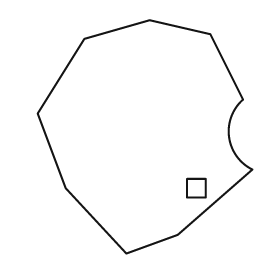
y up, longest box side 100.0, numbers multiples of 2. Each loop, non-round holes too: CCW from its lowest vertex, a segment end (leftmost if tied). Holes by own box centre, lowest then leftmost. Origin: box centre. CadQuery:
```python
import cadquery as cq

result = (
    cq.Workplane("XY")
    .moveTo(-8.0, -50.0)
    .lineTo(14.0, -42.0)
    .lineTo(46.0, -14.0)
    .threePointArc((36.0, 0.0), (42.0, 16.0))
    .lineTo(28.0, 44.0)
    .lineTo(2.0, 50.0)
    .lineTo(-26.0, 42.0)
    .lineTo(-46.0, 10.0)
    .lineTo(-34.0, -22.0)
    .close()
    .moveTo(18.0, -26.0)
    .lineTo(26.0, -26.0)
    .lineTo(26.0, -18.0)
    .lineTo(18.0, -18.0)
    .close()
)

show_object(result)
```